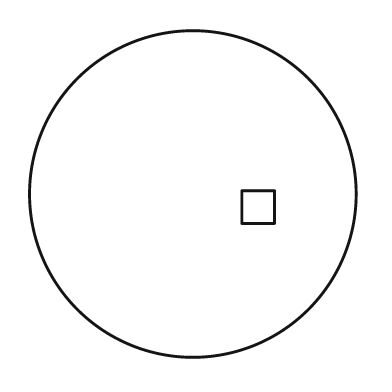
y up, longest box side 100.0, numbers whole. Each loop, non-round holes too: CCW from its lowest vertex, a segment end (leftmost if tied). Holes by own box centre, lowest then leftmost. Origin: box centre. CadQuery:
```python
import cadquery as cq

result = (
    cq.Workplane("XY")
    .moveTo(0.0, 0.0)
    .circle(50.0)
    .moveTo(15.0, -9.0)
    .lineTo(25.0, -9.0)
    .lineTo(25.0, 1.0)
    .lineTo(15.0, 1.0)
    .close()
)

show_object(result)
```